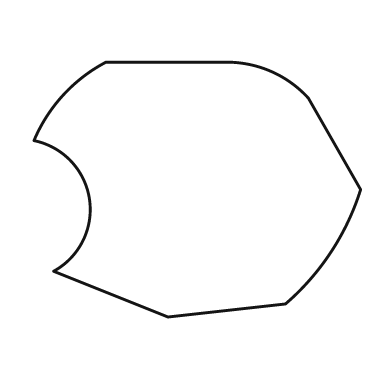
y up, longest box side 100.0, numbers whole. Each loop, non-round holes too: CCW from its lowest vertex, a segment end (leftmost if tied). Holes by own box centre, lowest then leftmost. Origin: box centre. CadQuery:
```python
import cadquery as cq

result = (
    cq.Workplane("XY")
    .moveTo(-9.0, -39.0)
    .lineTo(27.0, -35.0)
    .threePointArc((41.0, -19.0), (50.0, 0.0))
    .lineTo(34.0, 28.0)
    .threePointArc((23.0, 36.0), (10.0, 39.0))
    .lineTo(-28.0, 39.0)
    .threePointArc((-41.0, 29.0), (-50.0, 15.0))
    .threePointArc((-33.0, -3.0), (-44.0, -25.0))
    .close()
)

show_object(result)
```